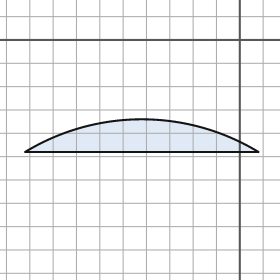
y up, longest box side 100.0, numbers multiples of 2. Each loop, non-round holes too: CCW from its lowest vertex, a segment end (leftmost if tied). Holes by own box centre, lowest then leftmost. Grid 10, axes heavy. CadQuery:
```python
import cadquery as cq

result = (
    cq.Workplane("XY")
    .moveTo(-92.0, -48.0)
    .lineTo(8.0, -48.0)
    .threePointArc((-42.0, -34.0), (-92.0, -48.0))
    .close()
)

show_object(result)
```